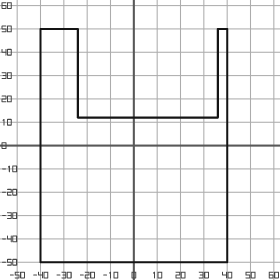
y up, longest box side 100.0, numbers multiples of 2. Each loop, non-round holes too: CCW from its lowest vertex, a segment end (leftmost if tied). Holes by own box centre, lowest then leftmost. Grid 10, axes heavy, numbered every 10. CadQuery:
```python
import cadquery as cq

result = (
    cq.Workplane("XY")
    .moveTo(-40.0, -50.0)
    .lineTo(40.0, -50.0)
    .lineTo(40.0, 50.0)
    .lineTo(36.0, 50.0)
    .lineTo(36.0, 12.0)
    .lineTo(-24.0, 12.0)
    .lineTo(-24.0, 50.0)
    .lineTo(-40.0, 50.0)
    .close()
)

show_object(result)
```